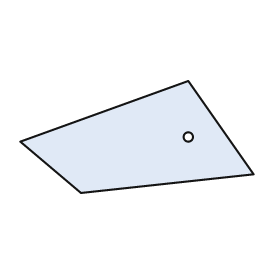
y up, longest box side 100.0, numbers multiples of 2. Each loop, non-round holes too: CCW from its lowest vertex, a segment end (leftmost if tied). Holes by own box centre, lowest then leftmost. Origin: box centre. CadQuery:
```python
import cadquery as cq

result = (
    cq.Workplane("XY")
    .moveTo(-24.0, -24.0)
    .lineTo(50.0, -16.0)
    .lineTo(22.0, 24.0)
    .lineTo(-50.0, -2.0)
    .close()
    .moveTo(22.0, 0.0)
    .circle(2.0)
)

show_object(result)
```